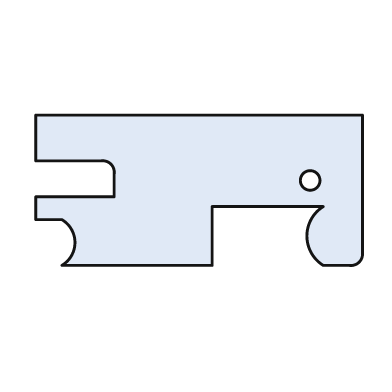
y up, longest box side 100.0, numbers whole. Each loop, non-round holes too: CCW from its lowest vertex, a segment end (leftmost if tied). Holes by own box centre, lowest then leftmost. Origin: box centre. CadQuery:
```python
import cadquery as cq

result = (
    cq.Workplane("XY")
    .moveTo(-42.0, -23.0)
    .lineTo(4.0, -23.0)
    .lineTo(4.0, -5.0)
    .lineTo(38.0, -5.0)
    .threePointArc((33.0, -14.0), (38.0, -23.0))
    .lineTo(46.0, -23.0)
    .threePointArc((49.0, -22.0), (50.0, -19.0))
    .lineTo(50.0, 23.0)
    .lineTo(-50.0, 23.0)
    .lineTo(-50.0, 9.0)
    .lineTo(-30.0, 9.0)
    .threePointArc((-27.0, 8.0), (-26.0, 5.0))
    .lineTo(-26.0, -2.0)
    .lineTo(-50.0, -2.0)
    .lineTo(-50.0, -9.0)
    .lineTo(-42.0, -9.0)
    .threePointArc((-38.0, -16.0), (-42.0, -23.0))
    .close()
    .moveTo(34.0, 3.0)
    .circle(3.0)
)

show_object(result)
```